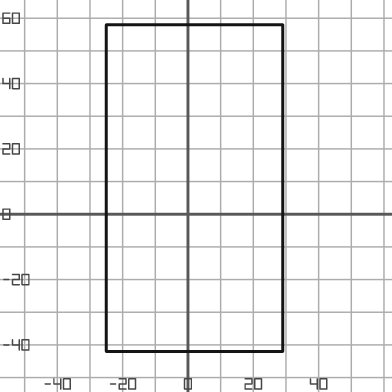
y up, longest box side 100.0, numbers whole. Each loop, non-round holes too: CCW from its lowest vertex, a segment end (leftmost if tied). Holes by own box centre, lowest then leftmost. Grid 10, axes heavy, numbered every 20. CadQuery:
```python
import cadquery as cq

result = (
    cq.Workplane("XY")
    .moveTo(-25.0, -42.0)
    .lineTo(29.0, -42.0)
    .lineTo(29.0, 58.0)
    .lineTo(-25.0, 58.0)
    .close()
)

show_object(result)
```